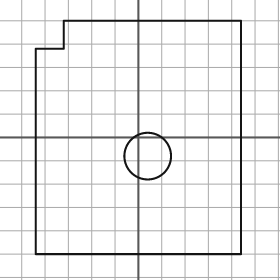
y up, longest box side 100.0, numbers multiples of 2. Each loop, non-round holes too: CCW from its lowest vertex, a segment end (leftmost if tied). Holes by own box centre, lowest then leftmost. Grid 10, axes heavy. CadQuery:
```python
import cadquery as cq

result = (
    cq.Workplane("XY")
    .moveTo(-44.0, -50.0)
    .lineTo(44.0, -50.0)
    .lineTo(44.0, 50.0)
    .lineTo(-32.0, 50.0)
    .lineTo(-32.0, 38.0)
    .lineTo(-44.0, 38.0)
    .close()
    .moveTo(4.0, -8.0)
    .circle(10.0)
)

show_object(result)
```